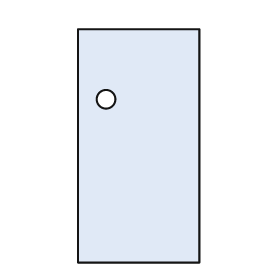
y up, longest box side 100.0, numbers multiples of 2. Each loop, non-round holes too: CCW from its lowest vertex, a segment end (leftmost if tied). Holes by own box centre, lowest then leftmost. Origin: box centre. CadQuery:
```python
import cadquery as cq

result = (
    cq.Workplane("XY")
    .moveTo(-26.0, -50.0)
    .lineTo(26.0, -50.0)
    .lineTo(26.0, 50.0)
    .lineTo(-26.0, 50.0)
    .close()
    .moveTo(-14.0, 20.0)
    .circle(4.0)
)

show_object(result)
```